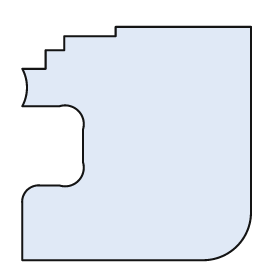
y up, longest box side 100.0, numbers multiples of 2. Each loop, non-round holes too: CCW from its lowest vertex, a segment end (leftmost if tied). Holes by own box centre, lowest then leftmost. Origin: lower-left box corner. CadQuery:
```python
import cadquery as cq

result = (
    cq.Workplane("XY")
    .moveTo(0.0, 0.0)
    .lineTo(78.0, 0.0)
    .threePointArc((92.0, 6.0), (98.0, 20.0))
    .lineTo(98.0, 100.0)
    .lineTo(40.0, 100.0)
    .lineTo(40.0, 96.0)
    .lineTo(18.0, 96.0)
    .lineTo(18.0, 90.0)
    .lineTo(10.0, 90.0)
    .lineTo(10.0, 82.0)
    .lineTo(0.0, 82.0)
    .threePointArc((2.0, 74.0), (0.0, 66.0))
    .lineTo(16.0, 66.0)
    .threePointArc((24.0, 64.0), (26.0, 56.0))
    .lineTo(26.0, 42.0)
    .threePointArc((24.0, 34.0), (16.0, 32.0))
    .lineTo(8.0, 32.0)
    .threePointArc((2.0, 30.0), (0.0, 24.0))
    .close()
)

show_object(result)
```